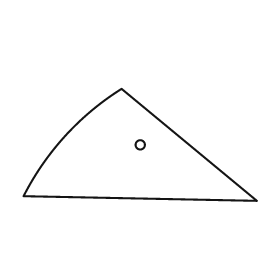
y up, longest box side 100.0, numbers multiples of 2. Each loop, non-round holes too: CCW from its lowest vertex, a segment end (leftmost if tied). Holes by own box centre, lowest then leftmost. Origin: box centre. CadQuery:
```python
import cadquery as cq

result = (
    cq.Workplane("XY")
    .moveTo(50.0, -24.0)
    .lineTo(-8.0, 24.0)
    .threePointArc((-32.0, 4.0), (-50.0, -22.0))
    .close()
    .moveTo(0.0, 0.0)
    .circle(2.0)
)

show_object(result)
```